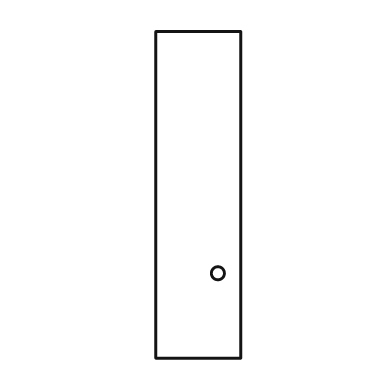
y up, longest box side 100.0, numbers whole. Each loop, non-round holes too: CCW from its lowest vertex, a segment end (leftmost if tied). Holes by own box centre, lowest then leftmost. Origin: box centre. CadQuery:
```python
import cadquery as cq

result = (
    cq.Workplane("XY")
    .moveTo(-13.0, -50.0)
    .lineTo(13.0, -50.0)
    .lineTo(13.0, 50.0)
    .lineTo(-13.0, 50.0)
    .close()
    .moveTo(6.0, -24.0)
    .circle(2.0)
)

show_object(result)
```